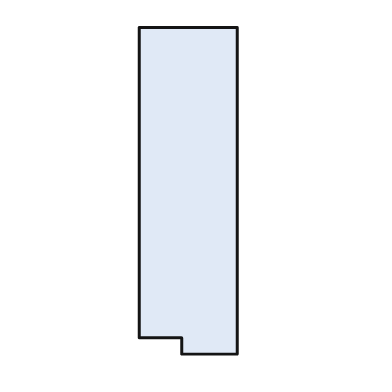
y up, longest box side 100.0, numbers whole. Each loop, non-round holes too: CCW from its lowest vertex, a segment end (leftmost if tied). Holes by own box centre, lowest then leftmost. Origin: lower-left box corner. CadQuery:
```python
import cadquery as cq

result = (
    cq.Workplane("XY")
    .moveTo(13.0, 0.0)
    .lineTo(30.0, 0.0)
    .lineTo(30.0, 100.0)
    .lineTo(0.0, 100.0)
    .lineTo(0.0, 5.0)
    .lineTo(13.0, 5.0)
    .close()
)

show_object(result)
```